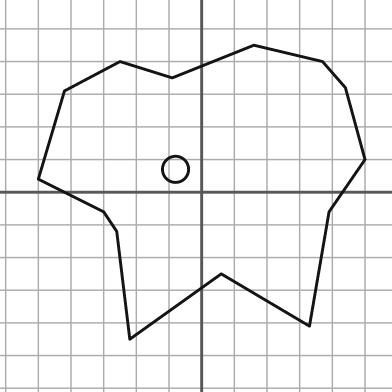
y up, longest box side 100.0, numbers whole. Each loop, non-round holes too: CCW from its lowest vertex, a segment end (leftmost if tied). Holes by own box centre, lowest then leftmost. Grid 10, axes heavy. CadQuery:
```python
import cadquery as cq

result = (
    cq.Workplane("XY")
    .moveTo(-22.0, -45.0)
    .lineTo(6.0, -25.0)
    .lineTo(33.0, -41.0)
    .lineTo(39.0, -6.0)
    .lineTo(50.0, 10.0)
    .lineTo(44.0, 32.0)
    .lineTo(37.0, 40.0)
    .lineTo(16.0, 45.0)
    .lineTo(-9.0, 35.0)
    .lineTo(-25.0, 40.0)
    .lineTo(-42.0, 31.0)
    .lineTo(-50.0, 4.0)
    .lineTo(-30.0, -6.0)
    .lineTo(-26.0, -12.0)
    .close()
    .moveTo(-8.0, 7.0)
    .circle(4.0)
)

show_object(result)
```